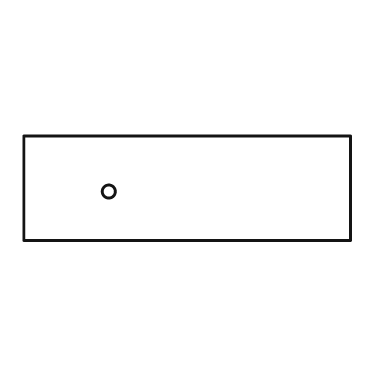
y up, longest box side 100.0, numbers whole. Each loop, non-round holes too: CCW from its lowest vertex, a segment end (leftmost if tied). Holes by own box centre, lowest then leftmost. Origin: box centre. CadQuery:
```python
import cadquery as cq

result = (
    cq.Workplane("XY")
    .moveTo(-50.0, -16.0)
    .lineTo(50.0, -16.0)
    .lineTo(50.0, 16.0)
    .lineTo(-50.0, 16.0)
    .close()
    .moveTo(-24.0, -1.0)
    .circle(2.0)
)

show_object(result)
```